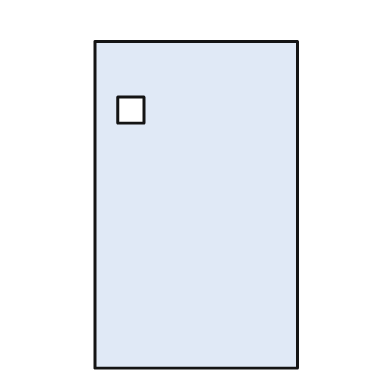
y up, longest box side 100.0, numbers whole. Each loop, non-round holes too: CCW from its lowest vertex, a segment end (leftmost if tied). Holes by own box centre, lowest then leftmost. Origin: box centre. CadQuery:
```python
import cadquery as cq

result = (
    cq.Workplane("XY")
    .moveTo(-31.0, -50.0)
    .lineTo(31.0, -50.0)
    .lineTo(31.0, 50.0)
    .lineTo(-31.0, 50.0)
    .close()
    .moveTo(-24.0, 25.0)
    .lineTo(-16.0, 25.0)
    .lineTo(-16.0, 33.0)
    .lineTo(-24.0, 33.0)
    .close()
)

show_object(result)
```